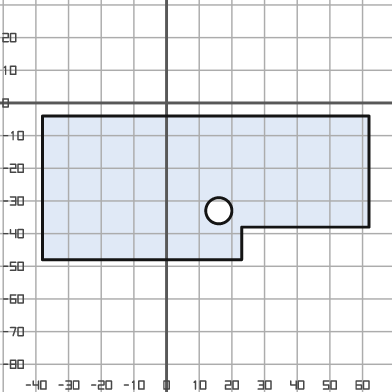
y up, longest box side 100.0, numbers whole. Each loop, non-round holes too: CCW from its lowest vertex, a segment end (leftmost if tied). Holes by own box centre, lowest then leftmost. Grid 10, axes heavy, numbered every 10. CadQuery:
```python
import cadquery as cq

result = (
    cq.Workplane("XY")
    .moveTo(-38.0, -48.0)
    .lineTo(23.0, -48.0)
    .lineTo(23.0, -38.0)
    .lineTo(62.0, -38.0)
    .lineTo(62.0, -4.0)
    .lineTo(-38.0, -4.0)
    .close()
    .moveTo(16.0, -33.0)
    .circle(4.0)
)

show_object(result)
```